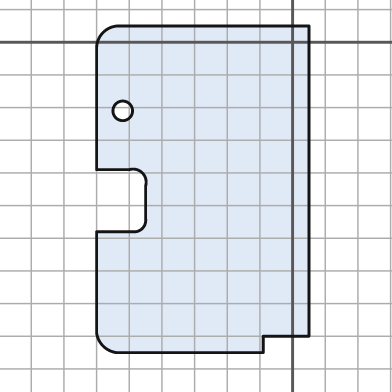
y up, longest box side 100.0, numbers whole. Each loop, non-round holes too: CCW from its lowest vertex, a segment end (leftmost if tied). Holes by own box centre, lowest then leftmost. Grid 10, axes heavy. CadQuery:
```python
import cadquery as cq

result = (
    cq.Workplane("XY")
    .moveTo(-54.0, -95.0)
    .lineTo(-9.0, -95.0)
    .lineTo(-9.0, -90.0)
    .lineTo(5.0, -90.0)
    .lineTo(5.0, 5.0)
    .lineTo(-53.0, 5.0)
    .threePointArc((-58.0, 3.0), (-60.0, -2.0))
    .lineTo(-60.0, -39.0)
    .lineTo(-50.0, -39.0)
    .threePointArc((-46.0, -40.0), (-45.0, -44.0))
    .lineTo(-45.0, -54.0)
    .threePointArc((-46.0, -57.0), (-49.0, -58.0))
    .lineTo(-60.0, -58.0)
    .lineTo(-60.0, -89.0)
    .threePointArc((-58.0, -93.0), (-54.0, -95.0))
    .close()
    .moveTo(-52.0, -21.0)
    .circle(3.0)
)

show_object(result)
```